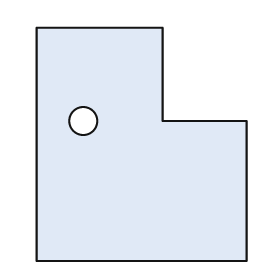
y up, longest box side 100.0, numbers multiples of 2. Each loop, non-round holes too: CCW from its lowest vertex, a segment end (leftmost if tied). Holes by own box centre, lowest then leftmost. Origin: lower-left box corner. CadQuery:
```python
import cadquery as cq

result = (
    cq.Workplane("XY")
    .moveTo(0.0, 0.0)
    .lineTo(90.0, 0.0)
    .lineTo(90.0, 60.0)
    .lineTo(54.0, 60.0)
    .lineTo(54.0, 100.0)
    .lineTo(0.0, 100.0)
    .close()
    .moveTo(20.0, 60.0)
    .circle(6.0)
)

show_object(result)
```